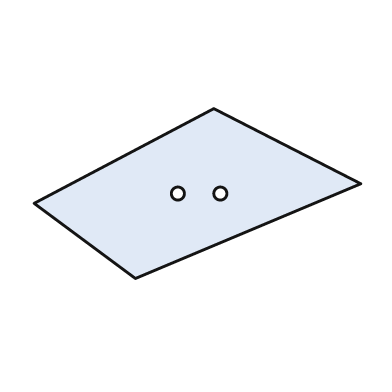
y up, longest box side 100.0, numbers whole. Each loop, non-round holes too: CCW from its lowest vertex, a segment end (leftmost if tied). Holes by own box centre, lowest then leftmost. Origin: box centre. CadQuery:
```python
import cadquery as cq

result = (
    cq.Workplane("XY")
    .moveTo(-19.0, -26.0)
    .lineTo(50.0, 3.0)
    .lineTo(5.0, 26.0)
    .lineTo(-50.0, -3.0)
    .close()
    .moveTo(-6.0, 0.0)
    .circle(2.0)
    .moveTo(7.0, 0.0)
    .circle(2.0)
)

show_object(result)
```